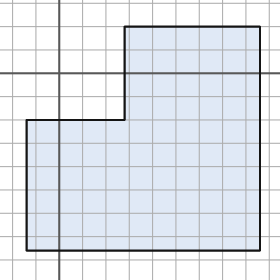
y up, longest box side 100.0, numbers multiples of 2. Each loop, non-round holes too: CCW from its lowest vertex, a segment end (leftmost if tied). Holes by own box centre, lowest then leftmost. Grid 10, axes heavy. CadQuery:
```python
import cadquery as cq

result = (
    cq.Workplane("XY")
    .moveTo(-14.0, -76.0)
    .lineTo(86.0, -76.0)
    .lineTo(86.0, 20.0)
    .lineTo(28.0, 20.0)
    .lineTo(28.0, -20.0)
    .lineTo(-14.0, -20.0)
    .close()
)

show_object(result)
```